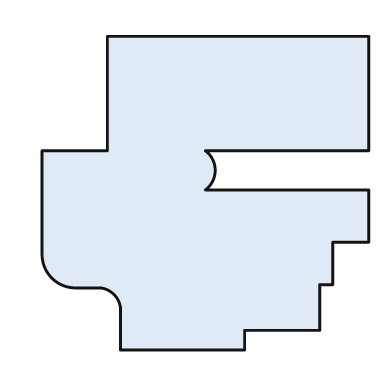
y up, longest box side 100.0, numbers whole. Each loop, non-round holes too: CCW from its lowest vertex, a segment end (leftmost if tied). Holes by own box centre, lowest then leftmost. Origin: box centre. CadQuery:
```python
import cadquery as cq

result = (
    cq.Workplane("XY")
    .moveTo(-26.0, -48.0)
    .lineTo(12.0, -48.0)
    .lineTo(12.0, -42.0)
    .lineTo(35.0, -42.0)
    .lineTo(35.0, -28.0)
    .lineTo(39.0, -28.0)
    .lineTo(39.0, -15.0)
    .lineTo(50.0, -15.0)
    .lineTo(50.0, 1.0)
    .lineTo(0.0, 1.0)
    .threePointArc((3.0, 7.0), (0.0, 13.0))
    .lineTo(50.0, 13.0)
    .lineTo(50.0, 48.0)
    .lineTo(-30.0, 48.0)
    .lineTo(-30.0, 13.0)
    .lineTo(-50.0, 13.0)
    .lineTo(-50.0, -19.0)
    .threePointArc((-47.0, -26.0), (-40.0, -29.0))
    .lineTo(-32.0, -29.0)
    .threePointArc((-28.0, -31.0), (-26.0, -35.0))
    .close()
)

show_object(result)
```